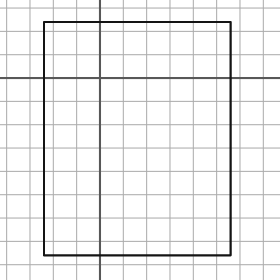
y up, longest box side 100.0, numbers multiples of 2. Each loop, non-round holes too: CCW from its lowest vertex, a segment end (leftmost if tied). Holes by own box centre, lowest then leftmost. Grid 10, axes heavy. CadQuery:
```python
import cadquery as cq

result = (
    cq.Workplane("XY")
    .moveTo(-24.0, -76.0)
    .lineTo(56.0, -76.0)
    .lineTo(56.0, 24.0)
    .lineTo(-24.0, 24.0)
    .close()
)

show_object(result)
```